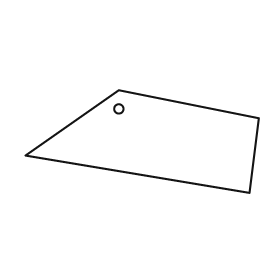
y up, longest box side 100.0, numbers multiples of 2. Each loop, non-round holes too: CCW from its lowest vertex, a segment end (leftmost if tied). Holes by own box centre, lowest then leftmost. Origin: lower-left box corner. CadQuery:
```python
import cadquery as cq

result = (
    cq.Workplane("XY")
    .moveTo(96.0, 0.0)
    .lineTo(100.0, 32.0)
    .lineTo(40.0, 44.0)
    .lineTo(0.0, 16.0)
    .close()
    .moveTo(40.0, 36.0)
    .circle(2.0)
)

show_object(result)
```